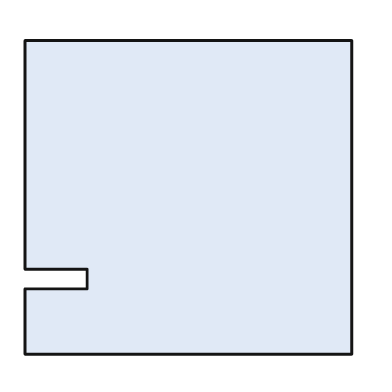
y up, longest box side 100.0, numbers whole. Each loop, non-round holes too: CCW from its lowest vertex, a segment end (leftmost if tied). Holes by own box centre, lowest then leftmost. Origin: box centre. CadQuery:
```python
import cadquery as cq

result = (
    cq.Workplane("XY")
    .moveTo(-50.0, -48.0)
    .lineTo(50.0, -48.0)
    .lineTo(50.0, 48.0)
    .lineTo(-50.0, 48.0)
    .lineTo(-50.0, -22.0)
    .lineTo(-31.0, -22.0)
    .lineTo(-31.0, -28.0)
    .lineTo(-50.0, -28.0)
    .close()
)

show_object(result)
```